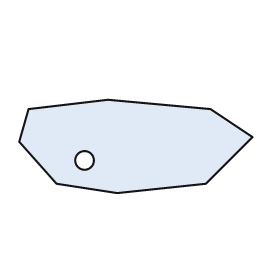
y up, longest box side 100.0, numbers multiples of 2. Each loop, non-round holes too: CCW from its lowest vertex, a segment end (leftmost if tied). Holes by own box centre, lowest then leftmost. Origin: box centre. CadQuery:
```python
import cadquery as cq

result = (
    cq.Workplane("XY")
    .moveTo(-8.0, -20.0)
    .lineTo(30.0, -16.0)
    .lineTo(50.0, 4.0)
    .lineTo(32.0, 16.0)
    .lineTo(-12.0, 20.0)
    .lineTo(-46.0, 16.0)
    .lineTo(-50.0, 2.0)
    .lineTo(-34.0, -16.0)
    .close()
    .moveTo(-22.0, -6.0)
    .circle(4.0)
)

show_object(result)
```